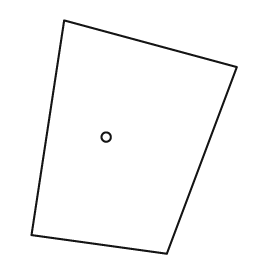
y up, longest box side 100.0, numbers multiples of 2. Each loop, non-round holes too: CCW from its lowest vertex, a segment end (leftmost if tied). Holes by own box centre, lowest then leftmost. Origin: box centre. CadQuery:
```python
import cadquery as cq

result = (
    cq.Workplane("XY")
    .moveTo(14.0, -50.0)
    .lineTo(44.0, 30.0)
    .lineTo(-30.0, 50.0)
    .lineTo(-44.0, -42.0)
    .close()
    .moveTo(-12.0, 0.0)
    .circle(2.0)
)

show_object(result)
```